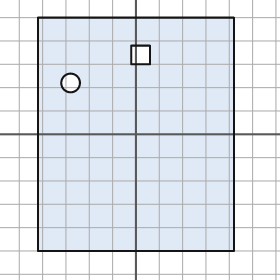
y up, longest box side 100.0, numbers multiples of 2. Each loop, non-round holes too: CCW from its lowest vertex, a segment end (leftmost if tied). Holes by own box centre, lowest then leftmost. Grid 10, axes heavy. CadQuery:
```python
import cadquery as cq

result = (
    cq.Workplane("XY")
    .moveTo(-42.0, -50.0)
    .lineTo(42.0, -50.0)
    .lineTo(42.0, 50.0)
    .lineTo(-42.0, 50.0)
    .close()
    .moveTo(-28.0, 22.0)
    .circle(4.0)
    .moveTo(-2.0, 30.0)
    .lineTo(6.0, 30.0)
    .lineTo(6.0, 38.0)
    .lineTo(-2.0, 38.0)
    .close()
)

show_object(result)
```